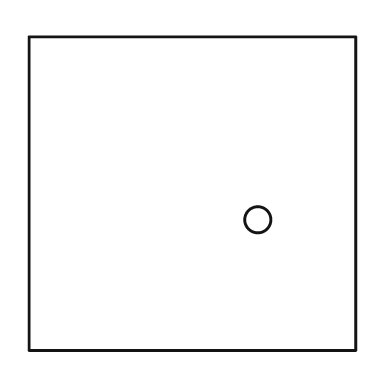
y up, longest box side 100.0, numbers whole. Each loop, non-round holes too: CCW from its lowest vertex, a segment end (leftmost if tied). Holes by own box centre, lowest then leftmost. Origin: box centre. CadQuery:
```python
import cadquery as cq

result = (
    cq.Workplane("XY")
    .moveTo(-50.0, -48.0)
    .lineTo(50.0, -48.0)
    .lineTo(50.0, 48.0)
    .lineTo(-50.0, 48.0)
    .close()
    .moveTo(20.0, -8.0)
    .circle(4.0)
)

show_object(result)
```